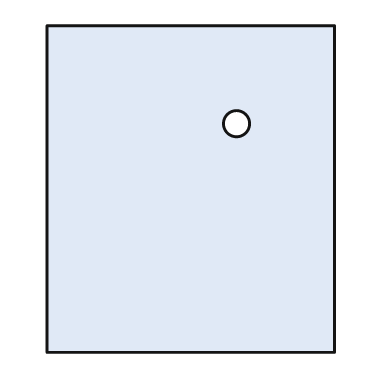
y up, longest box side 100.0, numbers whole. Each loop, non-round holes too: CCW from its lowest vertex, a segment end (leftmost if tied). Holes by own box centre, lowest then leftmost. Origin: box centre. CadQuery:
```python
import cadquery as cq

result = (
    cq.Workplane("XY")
    .moveTo(-44.0, -50.0)
    .lineTo(44.0, -50.0)
    .lineTo(44.0, 50.0)
    .lineTo(-44.0, 50.0)
    .close()
    .moveTo(14.0, 20.0)
    .circle(4.0)
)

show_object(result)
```